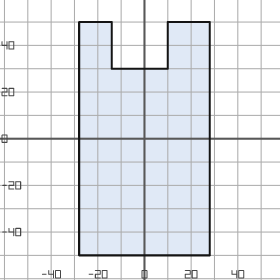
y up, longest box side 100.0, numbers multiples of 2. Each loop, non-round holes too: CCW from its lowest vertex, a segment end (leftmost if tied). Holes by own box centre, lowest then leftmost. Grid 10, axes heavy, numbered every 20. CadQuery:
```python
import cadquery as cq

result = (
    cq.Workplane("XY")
    .moveTo(-28.0, -50.0)
    .lineTo(28.0, -50.0)
    .lineTo(28.0, 50.0)
    .lineTo(10.0, 50.0)
    .lineTo(10.0, 30.0)
    .lineTo(-14.0, 30.0)
    .lineTo(-14.0, 50.0)
    .lineTo(-28.0, 50.0)
    .close()
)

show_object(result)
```